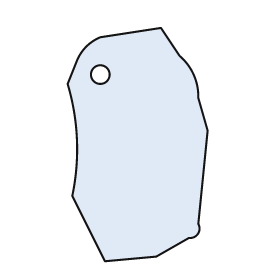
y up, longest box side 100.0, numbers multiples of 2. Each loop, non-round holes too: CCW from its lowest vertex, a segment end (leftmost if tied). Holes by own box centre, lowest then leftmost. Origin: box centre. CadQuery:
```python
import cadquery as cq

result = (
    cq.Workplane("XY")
    .moveTo(-14.0, -50.0)
    .lineTo(8.0, -48.0)
    .lineTo(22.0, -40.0)
    .threePointArc((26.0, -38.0), (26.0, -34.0))
    .lineTo(30.0, 6.0)
    .lineTo(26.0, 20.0)
    .threePointArc((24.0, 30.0), (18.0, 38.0))
    .lineTo(10.0, 50.0)
    .lineTo(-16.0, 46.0)
    .threePointArc((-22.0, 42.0), (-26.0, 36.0))
    .lineTo(-30.0, 26.0)
    .threePointArc((-26.0, 2.0), (-28.0, -22.0))
    .close()
    .moveTo(-16.0, 30.0)
    .circle(4.0)
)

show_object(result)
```